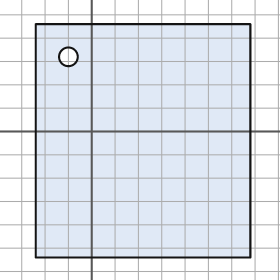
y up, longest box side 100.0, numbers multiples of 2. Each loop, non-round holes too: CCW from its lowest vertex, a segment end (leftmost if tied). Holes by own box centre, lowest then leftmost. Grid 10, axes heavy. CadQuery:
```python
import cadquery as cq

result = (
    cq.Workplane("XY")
    .moveTo(-24.0, -54.0)
    .lineTo(68.0, -54.0)
    .lineTo(68.0, 46.0)
    .lineTo(-24.0, 46.0)
    .close()
    .moveTo(-10.0, 32.0)
    .circle(4.0)
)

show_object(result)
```